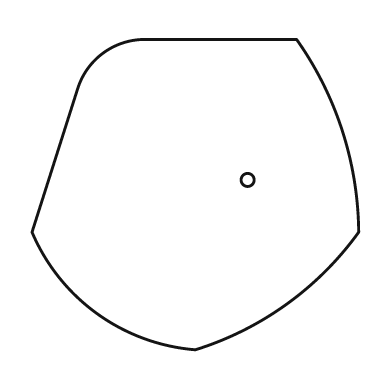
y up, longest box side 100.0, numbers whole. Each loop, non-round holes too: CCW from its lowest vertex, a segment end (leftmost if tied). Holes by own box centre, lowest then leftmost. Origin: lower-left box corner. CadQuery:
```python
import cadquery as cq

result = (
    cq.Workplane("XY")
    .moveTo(50.0, 0.0)
    .threePointArc((78.0, 14.0), (100.0, 36.0))
    .threePointArc((95.0, 67.0), (81.0, 95.0))
    .lineTo(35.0, 95.0)
    .threePointArc((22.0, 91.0), (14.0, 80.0))
    .lineTo(0.0, 36.0)
    .threePointArc((20.0, 11.0), (50.0, 0.0))
    .close()
    .moveTo(66.0, 52.0)
    .circle(2.0)
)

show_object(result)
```